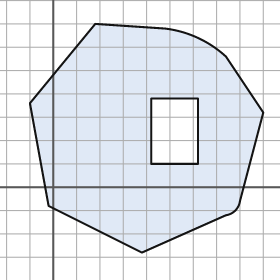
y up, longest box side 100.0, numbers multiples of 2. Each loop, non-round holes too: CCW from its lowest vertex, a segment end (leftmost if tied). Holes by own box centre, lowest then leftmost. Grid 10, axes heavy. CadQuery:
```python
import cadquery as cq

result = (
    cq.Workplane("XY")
    .moveTo(38.0, -28.0)
    .lineTo(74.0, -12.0)
    .threePointArc((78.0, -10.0), (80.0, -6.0))
    .lineTo(90.0, 32.0)
    .lineTo(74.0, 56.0)
    .threePointArc((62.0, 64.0), (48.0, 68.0))
    .lineTo(18.0, 70.0)
    .lineTo(-10.0, 36.0)
    .lineTo(-2.0, -8.0)
    .close()
    .moveTo(42.0, 10.0)
    .lineTo(62.0, 10.0)
    .lineTo(62.0, 38.0)
    .lineTo(42.0, 38.0)
    .close()
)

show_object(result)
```